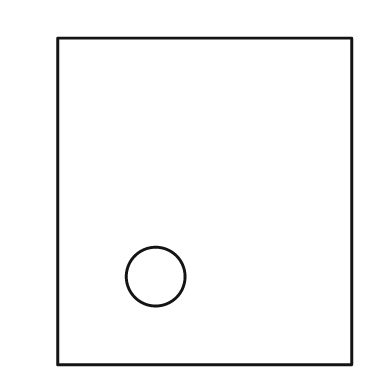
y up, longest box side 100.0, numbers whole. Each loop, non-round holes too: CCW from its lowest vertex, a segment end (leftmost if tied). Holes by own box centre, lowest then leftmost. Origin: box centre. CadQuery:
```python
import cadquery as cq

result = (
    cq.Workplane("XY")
    .moveTo(-45.0, -50.0)
    .lineTo(45.0, -50.0)
    .lineTo(45.0, 50.0)
    .lineTo(-45.0, 50.0)
    .close()
    .moveTo(-15.0, -23.0)
    .circle(9.0)
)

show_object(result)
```